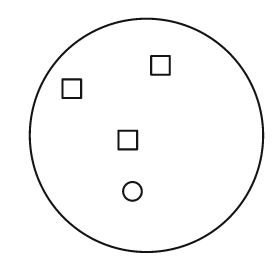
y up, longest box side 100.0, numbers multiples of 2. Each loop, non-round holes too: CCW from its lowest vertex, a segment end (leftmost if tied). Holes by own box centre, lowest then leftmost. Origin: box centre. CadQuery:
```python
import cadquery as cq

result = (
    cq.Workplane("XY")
    .moveTo(0.0, 0.0)
    .circle(50.0)
    .moveTo(-6.0, -24.0)
    .circle(4.0)
    .moveTo(-12.0, -6.0)
    .lineTo(-4.0, -6.0)
    .lineTo(-4.0, 2.0)
    .lineTo(-12.0, 2.0)
    .close()
    .moveTo(-36.0, 16.0)
    .lineTo(-28.0, 16.0)
    .lineTo(-28.0, 24.0)
    .lineTo(-36.0, 24.0)
    .close()
    .moveTo(2.0, 26.0)
    .lineTo(10.0, 26.0)
    .lineTo(10.0, 34.0)
    .lineTo(2.0, 34.0)
    .close()
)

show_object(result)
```